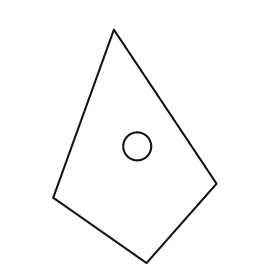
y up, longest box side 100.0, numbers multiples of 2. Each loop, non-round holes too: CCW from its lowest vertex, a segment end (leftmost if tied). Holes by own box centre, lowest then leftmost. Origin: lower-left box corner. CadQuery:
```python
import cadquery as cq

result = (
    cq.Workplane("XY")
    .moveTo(40.0, 0.0)
    .lineTo(70.0, 34.0)
    .lineTo(26.0, 100.0)
    .lineTo(0.0, 28.0)
    .close()
    .moveTo(36.0, 50.0)
    .circle(6.0)
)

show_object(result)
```